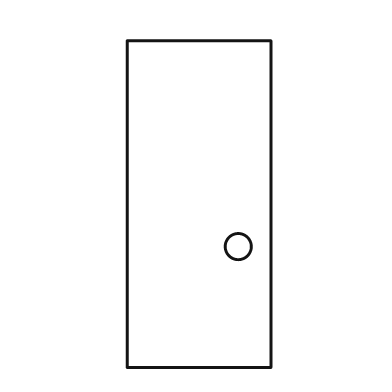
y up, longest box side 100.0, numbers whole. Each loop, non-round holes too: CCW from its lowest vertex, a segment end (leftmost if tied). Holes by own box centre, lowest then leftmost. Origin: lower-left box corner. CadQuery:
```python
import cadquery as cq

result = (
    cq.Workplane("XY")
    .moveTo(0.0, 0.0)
    .lineTo(44.0, 0.0)
    .lineTo(44.0, 100.0)
    .lineTo(0.0, 100.0)
    .close()
    .moveTo(34.0, 37.0)
    .circle(4.0)
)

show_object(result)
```